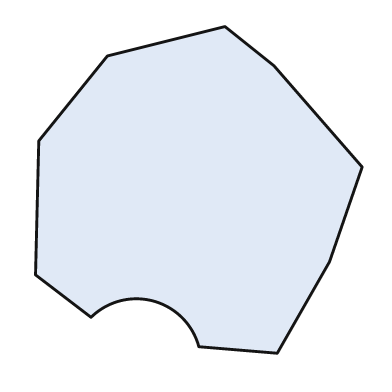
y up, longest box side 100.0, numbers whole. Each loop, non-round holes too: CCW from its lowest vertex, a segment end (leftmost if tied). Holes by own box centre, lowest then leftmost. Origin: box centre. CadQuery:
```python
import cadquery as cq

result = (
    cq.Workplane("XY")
    .moveTo(24.0, -50.0)
    .lineTo(40.0, -22.0)
    .lineTo(50.0, 7.0)
    .lineTo(23.0, 38.0)
    .lineTo(8.0, 50.0)
    .lineTo(-28.0, 41.0)
    .lineTo(-49.0, 15.0)
    .lineTo(-50.0, -26.0)
    .lineTo(-33.0, -39.0)
    .threePointArc((-14.0, -34.0), (0.0, -48.0))
    .close()
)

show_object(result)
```